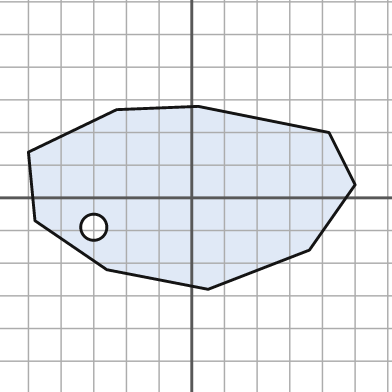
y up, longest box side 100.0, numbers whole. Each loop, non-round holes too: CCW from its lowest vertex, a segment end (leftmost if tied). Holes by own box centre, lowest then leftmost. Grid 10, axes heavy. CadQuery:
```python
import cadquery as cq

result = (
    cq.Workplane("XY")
    .moveTo(5.0, -28.0)
    .lineTo(36.0, -16.0)
    .lineTo(50.0, 4.0)
    .lineTo(42.0, 20.0)
    .lineTo(2.0, 28.0)
    .lineTo(-23.0, 27.0)
    .lineTo(-50.0, 14.0)
    .lineTo(-48.0, -7.0)
    .lineTo(-26.0, -22.0)
    .close()
    .moveTo(-30.0, -9.0)
    .circle(4.0)
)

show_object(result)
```